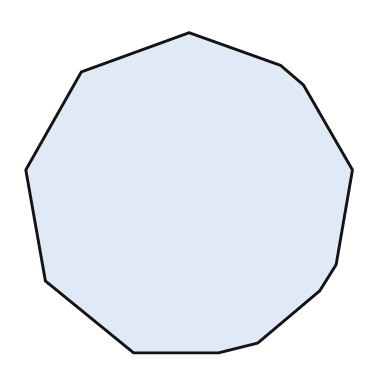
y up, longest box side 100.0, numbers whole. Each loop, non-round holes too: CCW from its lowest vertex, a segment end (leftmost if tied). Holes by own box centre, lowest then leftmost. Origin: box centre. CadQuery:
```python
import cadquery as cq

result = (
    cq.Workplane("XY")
    .moveTo(-17.0, -49.0)
    .lineTo(9.0, -49.0)
    .lineTo(21.0, -46.0)
    .lineTo(40.0, -30.0)
    .lineTo(45.0, -22.0)
    .lineTo(50.0, 7.0)
    .lineTo(35.0, 33.0)
    .lineTo(28.0, 39.0)
    .lineTo(0.0, 49.0)
    .lineTo(-33.0, 37.0)
    .lineTo(-50.0, 7.0)
    .lineTo(-44.0, -27.0)
    .close()
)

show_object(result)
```